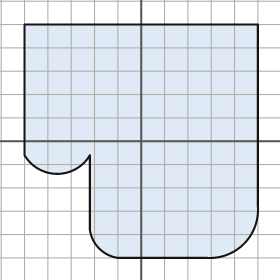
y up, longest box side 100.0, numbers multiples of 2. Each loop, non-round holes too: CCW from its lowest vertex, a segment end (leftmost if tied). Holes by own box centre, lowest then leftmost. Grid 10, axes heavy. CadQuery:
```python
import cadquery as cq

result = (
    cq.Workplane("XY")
    .moveTo(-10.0, -50.0)
    .lineTo(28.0, -50.0)
    .threePointArc((44.0, -44.0), (50.0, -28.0))
    .lineTo(50.0, 50.0)
    .lineTo(-50.0, 50.0)
    .lineTo(-50.0, -6.0)
    .threePointArc((-36.0, -14.0), (-22.0, -6.0))
    .lineTo(-22.0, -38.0)
    .threePointArc((-18.0, -46.0), (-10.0, -50.0))
    .close()
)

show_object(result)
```